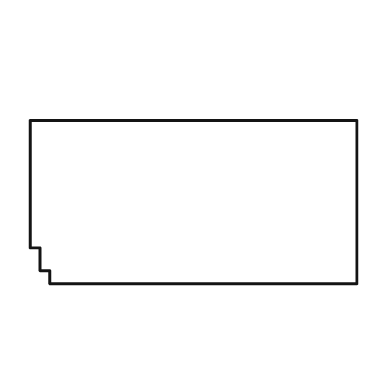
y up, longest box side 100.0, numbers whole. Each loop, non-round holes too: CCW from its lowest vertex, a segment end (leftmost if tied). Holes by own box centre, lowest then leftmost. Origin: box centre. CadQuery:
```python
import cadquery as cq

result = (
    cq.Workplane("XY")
    .moveTo(-44.0, -25.0)
    .lineTo(50.0, -25.0)
    .lineTo(50.0, 25.0)
    .lineTo(-50.0, 25.0)
    .lineTo(-50.0, -14.0)
    .lineTo(-47.0, -14.0)
    .lineTo(-47.0, -21.0)
    .lineTo(-44.0, -21.0)
    .close()
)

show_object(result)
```